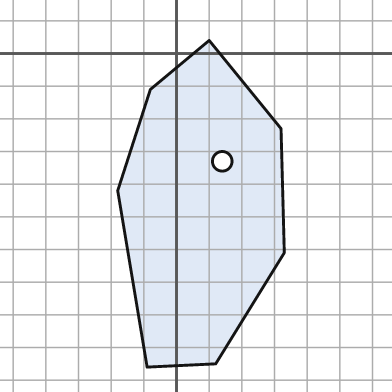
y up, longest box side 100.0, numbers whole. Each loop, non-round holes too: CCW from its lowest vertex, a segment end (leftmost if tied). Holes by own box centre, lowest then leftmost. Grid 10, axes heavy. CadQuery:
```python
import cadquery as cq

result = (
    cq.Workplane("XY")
    .moveTo(-9.0, -96.0)
    .lineTo(12.0, -95.0)
    .lineTo(33.0, -61.0)
    .lineTo(32.0, -23.0)
    .lineTo(10.0, 4.0)
    .lineTo(-8.0, -11.0)
    .lineTo(-18.0, -42.0)
    .close()
    .moveTo(14.0, -33.0)
    .circle(3.0)
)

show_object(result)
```